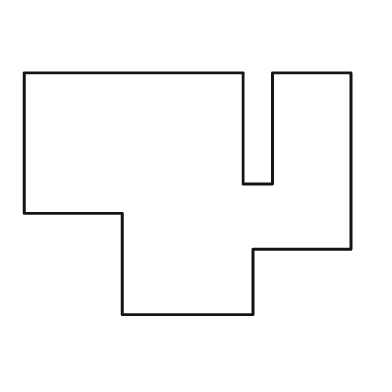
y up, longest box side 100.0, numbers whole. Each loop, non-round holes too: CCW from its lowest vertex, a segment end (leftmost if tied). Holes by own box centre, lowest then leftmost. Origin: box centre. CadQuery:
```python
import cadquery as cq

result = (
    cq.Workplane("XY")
    .moveTo(-20.0, -37.0)
    .lineTo(20.0, -37.0)
    .lineTo(20.0, -17.0)
    .lineTo(50.0, -17.0)
    .lineTo(50.0, 37.0)
    .lineTo(26.0, 37.0)
    .lineTo(26.0, 3.0)
    .lineTo(17.0, 3.0)
    .lineTo(17.0, 37.0)
    .lineTo(-50.0, 37.0)
    .lineTo(-50.0, -6.0)
    .lineTo(-20.0, -6.0)
    .close()
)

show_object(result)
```